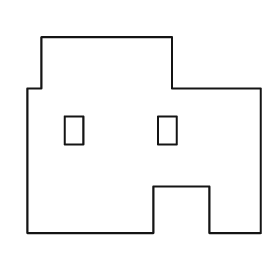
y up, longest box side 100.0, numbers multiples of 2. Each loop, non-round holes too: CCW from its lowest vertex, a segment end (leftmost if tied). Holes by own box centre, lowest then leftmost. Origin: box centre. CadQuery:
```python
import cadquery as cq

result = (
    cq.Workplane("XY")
    .moveTo(-50.0, -42.0)
    .lineTo(4.0, -42.0)
    .lineTo(4.0, -22.0)
    .lineTo(28.0, -22.0)
    .lineTo(28.0, -42.0)
    .lineTo(50.0, -42.0)
    .lineTo(50.0, 20.0)
    .lineTo(12.0, 20.0)
    .lineTo(12.0, 42.0)
    .lineTo(-44.0, 42.0)
    .lineTo(-44.0, 20.0)
    .lineTo(-50.0, 20.0)
    .close()
    .moveTo(-34.0, -4.0)
    .lineTo(-26.0, -4.0)
    .lineTo(-26.0, 8.0)
    .lineTo(-34.0, 8.0)
    .close()
    .moveTo(6.0, -4.0)
    .lineTo(14.0, -4.0)
    .lineTo(14.0, 8.0)
    .lineTo(6.0, 8.0)
    .close()
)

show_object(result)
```